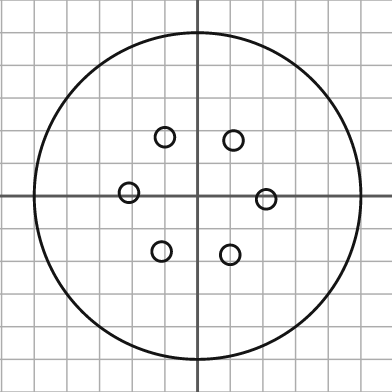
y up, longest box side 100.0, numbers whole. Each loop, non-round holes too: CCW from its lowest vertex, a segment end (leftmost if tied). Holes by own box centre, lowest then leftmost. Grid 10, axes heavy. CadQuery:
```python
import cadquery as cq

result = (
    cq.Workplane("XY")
    .moveTo(0.0, 0.0)
    .circle(50.0)
    .moveTo(10.0, -18.0)
    .circle(3.0)
    .moveTo(-11.0, -17.0)
    .circle(3.0)
    .moveTo(21.0, -1.0)
    .circle(3.0)
    .moveTo(-21.0, 1.0)
    .circle(3.0)
    .moveTo(11.0, 17.0)
    .circle(3.0)
    .moveTo(-10.0, 18.0)
    .circle(3.0)
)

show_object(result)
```